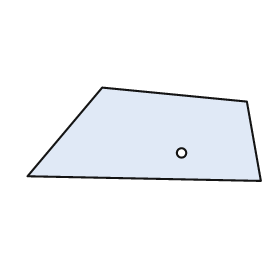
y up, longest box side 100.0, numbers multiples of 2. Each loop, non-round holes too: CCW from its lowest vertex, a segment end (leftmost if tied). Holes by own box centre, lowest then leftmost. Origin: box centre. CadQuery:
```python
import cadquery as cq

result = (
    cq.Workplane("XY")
    .moveTo(50.0, -20.0)
    .lineTo(44.0, 14.0)
    .lineTo(-18.0, 20.0)
    .lineTo(-50.0, -18.0)
    .close()
    .moveTo(16.0, -8.0)
    .circle(2.0)
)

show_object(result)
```